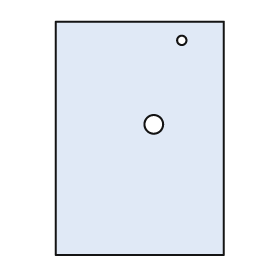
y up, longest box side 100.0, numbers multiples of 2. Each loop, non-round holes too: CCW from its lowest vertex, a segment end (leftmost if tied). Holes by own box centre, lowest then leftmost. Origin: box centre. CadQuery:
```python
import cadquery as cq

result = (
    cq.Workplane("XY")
    .moveTo(-36.0, -50.0)
    .lineTo(36.0, -50.0)
    .lineTo(36.0, 50.0)
    .lineTo(-36.0, 50.0)
    .close()
    .moveTo(6.0, 6.0)
    .circle(4.0)
    .moveTo(18.0, 42.0)
    .circle(2.0)
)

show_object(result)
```